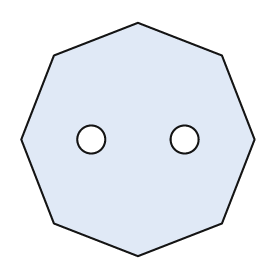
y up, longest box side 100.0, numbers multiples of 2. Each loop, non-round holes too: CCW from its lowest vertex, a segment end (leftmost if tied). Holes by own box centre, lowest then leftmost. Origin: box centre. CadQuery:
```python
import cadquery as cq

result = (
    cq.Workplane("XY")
    .moveTo(0.0, -50.0)
    .lineTo(36.0, -36.0)
    .lineTo(50.0, 0.0)
    .lineTo(36.0, 36.0)
    .lineTo(0.0, 50.0)
    .lineTo(-36.0, 36.0)
    .lineTo(-50.0, 0.0)
    .lineTo(-36.0, -36.0)
    .close()
    .moveTo(-20.0, 0.0)
    .circle(6.0)
    .moveTo(20.0, 0.0)
    .circle(6.0)
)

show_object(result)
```